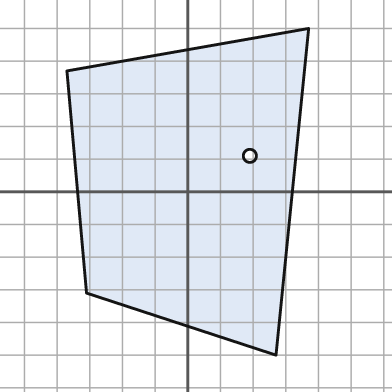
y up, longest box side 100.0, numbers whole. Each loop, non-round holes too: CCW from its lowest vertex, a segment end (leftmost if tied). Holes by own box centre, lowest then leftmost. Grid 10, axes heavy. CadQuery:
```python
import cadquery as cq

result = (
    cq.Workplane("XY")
    .moveTo(27.0, -50.0)
    .lineTo(37.0, 50.0)
    .lineTo(-37.0, 37.0)
    .lineTo(-31.0, -31.0)
    .close()
    .moveTo(19.0, 11.0)
    .circle(2.0)
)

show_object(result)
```